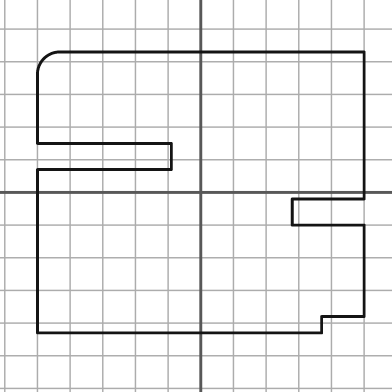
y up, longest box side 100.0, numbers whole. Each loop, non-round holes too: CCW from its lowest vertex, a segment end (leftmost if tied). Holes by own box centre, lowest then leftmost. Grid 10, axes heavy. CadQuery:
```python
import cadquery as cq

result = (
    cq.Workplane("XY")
    .moveTo(-50.0, -43.0)
    .lineTo(37.0, -43.0)
    .lineTo(37.0, -38.0)
    .lineTo(50.0, -38.0)
    .lineTo(50.0, -10.0)
    .lineTo(28.0, -10.0)
    .lineTo(28.0, -2.0)
    .lineTo(50.0, -2.0)
    .lineTo(50.0, 43.0)
    .lineTo(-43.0, 43.0)
    .threePointArc((-48.0, 41.0), (-50.0, 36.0))
    .lineTo(-50.0, 15.0)
    .lineTo(-9.0, 15.0)
    .lineTo(-9.0, 7.0)
    .lineTo(-50.0, 7.0)
    .close()
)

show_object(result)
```